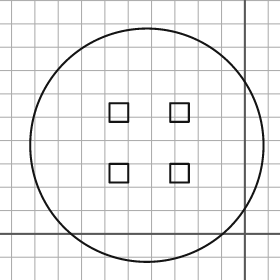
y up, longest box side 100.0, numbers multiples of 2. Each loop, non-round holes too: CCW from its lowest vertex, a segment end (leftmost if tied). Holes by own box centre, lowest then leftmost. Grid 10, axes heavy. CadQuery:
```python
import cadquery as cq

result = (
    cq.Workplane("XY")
    .moveTo(-42.0, 38.0)
    .circle(50.0)
    .moveTo(-58.0, 22.0)
    .lineTo(-50.0, 22.0)
    .lineTo(-50.0, 30.0)
    .lineTo(-58.0, 30.0)
    .close()
    .moveTo(-32.0, 22.0)
    .lineTo(-24.0, 22.0)
    .lineTo(-24.0, 30.0)
    .lineTo(-32.0, 30.0)
    .close()
    .moveTo(-58.0, 48.0)
    .lineTo(-50.0, 48.0)
    .lineTo(-50.0, 56.0)
    .lineTo(-58.0, 56.0)
    .close()
    .moveTo(-32.0, 48.0)
    .lineTo(-24.0, 48.0)
    .lineTo(-24.0, 56.0)
    .lineTo(-32.0, 56.0)
    .close()
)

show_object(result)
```